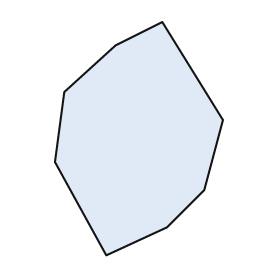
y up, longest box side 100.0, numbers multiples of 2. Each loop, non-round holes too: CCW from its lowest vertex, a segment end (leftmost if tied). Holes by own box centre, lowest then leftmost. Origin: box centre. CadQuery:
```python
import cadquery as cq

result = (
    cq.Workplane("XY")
    .moveTo(-14.0, -50.0)
    .lineTo(12.0, -38.0)
    .lineTo(28.0, -22.0)
    .lineTo(36.0, 8.0)
    .lineTo(10.0, 50.0)
    .lineTo(-10.0, 40.0)
    .lineTo(-32.0, 20.0)
    .lineTo(-36.0, -10.0)
    .close()
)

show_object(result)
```